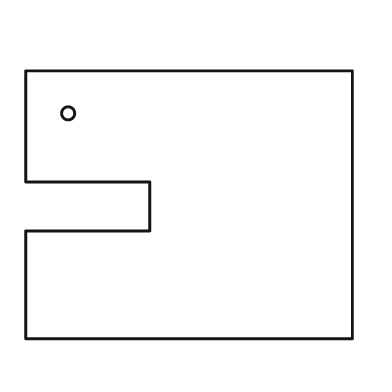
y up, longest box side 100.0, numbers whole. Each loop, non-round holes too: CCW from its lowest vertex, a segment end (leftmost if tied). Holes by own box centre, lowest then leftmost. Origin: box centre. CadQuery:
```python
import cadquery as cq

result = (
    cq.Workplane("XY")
    .moveTo(-50.0, -41.0)
    .lineTo(50.0, -41.0)
    .lineTo(50.0, 41.0)
    .lineTo(-50.0, 41.0)
    .lineTo(-50.0, 7.0)
    .lineTo(-12.0, 7.0)
    .lineTo(-12.0, -8.0)
    .lineTo(-50.0, -8.0)
    .close()
    .moveTo(-37.0, 28.0)
    .circle(2.0)
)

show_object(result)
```